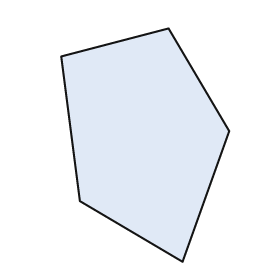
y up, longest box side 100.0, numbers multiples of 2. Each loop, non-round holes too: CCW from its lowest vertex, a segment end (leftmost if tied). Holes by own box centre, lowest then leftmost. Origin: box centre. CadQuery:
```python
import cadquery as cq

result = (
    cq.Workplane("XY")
    .moveTo(16.0, -50.0)
    .lineTo(36.0, 6.0)
    .lineTo(10.0, 50.0)
    .lineTo(-36.0, 38.0)
    .lineTo(-28.0, -24.0)
    .close()
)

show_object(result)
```